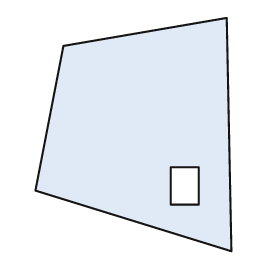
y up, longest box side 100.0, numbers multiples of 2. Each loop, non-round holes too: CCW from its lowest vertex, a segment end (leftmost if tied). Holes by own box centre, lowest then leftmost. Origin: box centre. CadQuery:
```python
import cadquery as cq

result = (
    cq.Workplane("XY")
    .moveTo(42.0, -50.0)
    .lineTo(40.0, 50.0)
    .lineTo(-30.0, 38.0)
    .lineTo(-42.0, -24.0)
    .close()
    .moveTo(16.0, -30.0)
    .lineTo(28.0, -30.0)
    .lineTo(28.0, -14.0)
    .lineTo(16.0, -14.0)
    .close()
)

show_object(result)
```